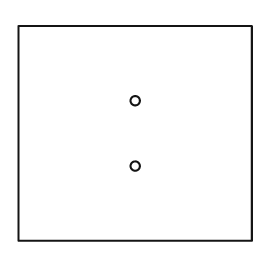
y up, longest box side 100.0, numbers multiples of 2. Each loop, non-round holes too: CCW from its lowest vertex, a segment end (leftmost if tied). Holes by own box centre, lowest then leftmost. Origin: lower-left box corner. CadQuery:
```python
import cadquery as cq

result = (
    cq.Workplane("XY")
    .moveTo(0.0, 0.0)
    .lineTo(100.0, 0.0)
    .lineTo(100.0, 92.0)
    .lineTo(0.0, 92.0)
    .close()
    .moveTo(50.0, 32.0)
    .circle(2.0)
    .moveTo(50.0, 60.0)
    .circle(2.0)
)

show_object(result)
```